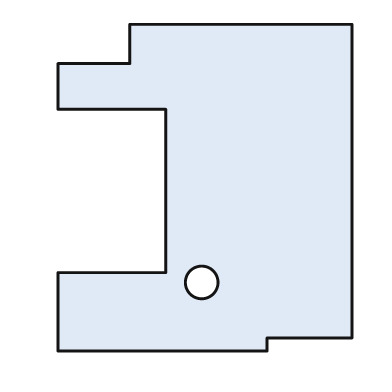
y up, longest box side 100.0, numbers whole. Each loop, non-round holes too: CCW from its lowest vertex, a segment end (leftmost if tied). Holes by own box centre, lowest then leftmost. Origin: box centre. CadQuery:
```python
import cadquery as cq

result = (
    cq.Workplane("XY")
    .moveTo(-45.0, -50.0)
    .lineTo(19.0, -50.0)
    .lineTo(19.0, -46.0)
    .lineTo(45.0, -46.0)
    .lineTo(45.0, 50.0)
    .lineTo(-23.0, 50.0)
    .lineTo(-23.0, 38.0)
    .lineTo(-45.0, 38.0)
    .lineTo(-45.0, 24.0)
    .lineTo(-12.0, 24.0)
    .lineTo(-12.0, -26.0)
    .lineTo(-45.0, -26.0)
    .close()
    .moveTo(-1.0, -29.0)
    .circle(5.0)
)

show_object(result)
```